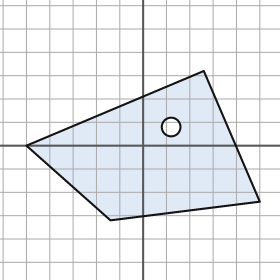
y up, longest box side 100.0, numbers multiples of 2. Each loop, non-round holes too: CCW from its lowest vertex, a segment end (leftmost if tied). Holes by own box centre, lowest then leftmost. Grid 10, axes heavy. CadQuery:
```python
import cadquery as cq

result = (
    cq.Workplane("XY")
    .moveTo(-14.0, -32.0)
    .lineTo(50.0, -24.0)
    .lineTo(26.0, 32.0)
    .lineTo(-50.0, 0.0)
    .close()
    .moveTo(12.0, 8.0)
    .circle(4.0)
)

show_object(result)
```